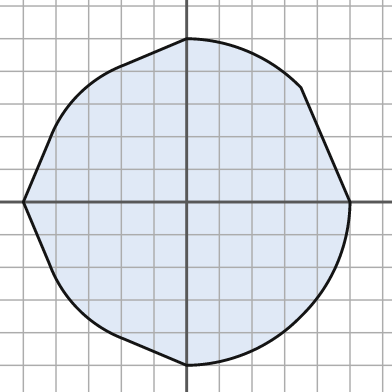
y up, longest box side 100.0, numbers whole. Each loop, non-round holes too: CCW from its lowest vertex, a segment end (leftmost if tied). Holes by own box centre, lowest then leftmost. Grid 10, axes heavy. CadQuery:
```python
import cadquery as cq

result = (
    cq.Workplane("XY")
    .moveTo(0.0, -50.0)
    .threePointArc((19.0, -46.0), (35.0, -35.0))
    .threePointArc((46.0, -19.0), (50.0, 0.0))
    .lineTo(35.0, 35.0)
    .threePointArc((19.0, 46.0), (0.0, 50.0))
    .lineTo(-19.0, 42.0)
    .threePointArc((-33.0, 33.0), (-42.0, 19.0))
    .lineTo(-50.0, 0.0)
    .lineTo(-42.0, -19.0)
    .threePointArc((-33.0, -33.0), (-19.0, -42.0))
    .close()
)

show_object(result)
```